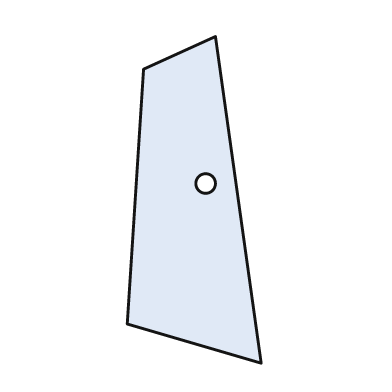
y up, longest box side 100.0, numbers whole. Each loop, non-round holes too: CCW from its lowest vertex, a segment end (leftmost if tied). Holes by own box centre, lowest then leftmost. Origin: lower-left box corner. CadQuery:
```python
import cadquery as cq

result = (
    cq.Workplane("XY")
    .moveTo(41.0, 0.0)
    .lineTo(27.0, 100.0)
    .lineTo(5.0, 90.0)
    .lineTo(0.0, 12.0)
    .close()
    .moveTo(24.0, 55.0)
    .circle(3.0)
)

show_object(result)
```